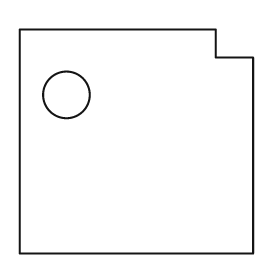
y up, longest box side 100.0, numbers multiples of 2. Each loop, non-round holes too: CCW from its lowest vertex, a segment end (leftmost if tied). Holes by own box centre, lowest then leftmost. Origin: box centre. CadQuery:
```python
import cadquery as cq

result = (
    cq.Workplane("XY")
    .moveTo(-50.0, -48.0)
    .lineTo(50.0, -48.0)
    .lineTo(50.0, 36.0)
    .lineTo(34.0, 36.0)
    .lineTo(34.0, 48.0)
    .lineTo(-50.0, 48.0)
    .close()
    .moveTo(-30.0, 20.0)
    .circle(10.0)
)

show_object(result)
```